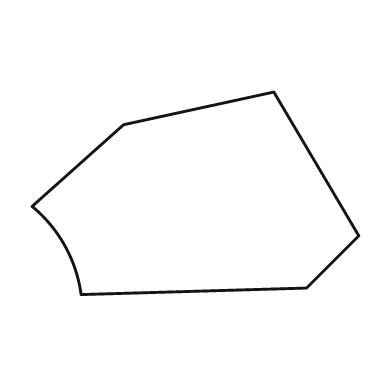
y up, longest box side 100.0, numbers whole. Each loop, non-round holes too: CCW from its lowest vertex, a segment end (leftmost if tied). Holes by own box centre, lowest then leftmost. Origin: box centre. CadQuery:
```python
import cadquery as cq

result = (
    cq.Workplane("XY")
    .moveTo(-35.0, -31.0)
    .lineTo(34.0, -29.0)
    .lineTo(50.0, -13.0)
    .lineTo(24.0, 31.0)
    .lineTo(-22.0, 21.0)
    .lineTo(-50.0, -4.0)
    .threePointArc((-40.0, -16.0), (-35.0, -31.0))
    .close()
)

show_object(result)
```